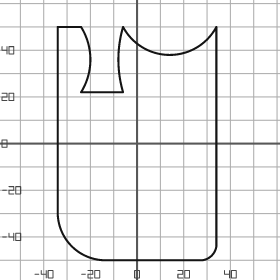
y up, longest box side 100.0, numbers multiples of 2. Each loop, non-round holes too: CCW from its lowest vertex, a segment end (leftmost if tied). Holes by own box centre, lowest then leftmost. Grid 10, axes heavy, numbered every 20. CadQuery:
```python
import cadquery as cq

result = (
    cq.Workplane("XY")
    .moveTo(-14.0, -50.0)
    .lineTo(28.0, -50.0)
    .threePointArc((32.0, -48.0), (34.0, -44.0))
    .lineTo(34.0, 50.0)
    .threePointArc((14.0, 38.0), (-6.0, 50.0))
    .threePointArc((-8.0, 36.0), (-6.0, 22.0))
    .lineTo(-24.0, 22.0)
    .threePointArc((-20.0, 36.0), (-24.0, 50.0))
    .lineTo(-34.0, 50.0)
    .lineTo(-34.0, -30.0)
    .threePointArc((-28.0, -44.0), (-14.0, -50.0))
    .close()
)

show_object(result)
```